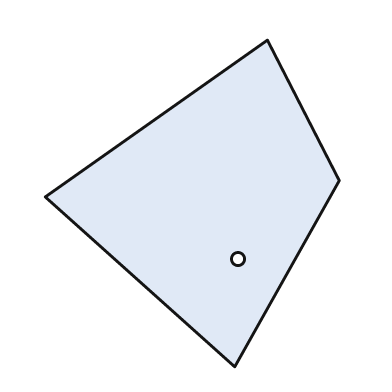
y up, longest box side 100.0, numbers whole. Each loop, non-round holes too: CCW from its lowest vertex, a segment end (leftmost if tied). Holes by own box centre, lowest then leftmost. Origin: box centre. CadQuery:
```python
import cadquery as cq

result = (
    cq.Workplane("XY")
    .moveTo(13.0, -50.0)
    .lineTo(45.0, 7.0)
    .lineTo(23.0, 50.0)
    .lineTo(-45.0, 2.0)
    .close()
    .moveTo(14.0, -17.0)
    .circle(2.0)
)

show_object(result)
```